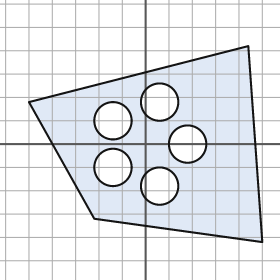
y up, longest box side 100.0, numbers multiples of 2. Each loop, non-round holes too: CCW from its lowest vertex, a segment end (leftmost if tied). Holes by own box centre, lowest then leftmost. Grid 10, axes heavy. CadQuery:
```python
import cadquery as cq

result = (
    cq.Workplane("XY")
    .moveTo(50.0, -42.0)
    .lineTo(44.0, 42.0)
    .lineTo(-50.0, 18.0)
    .lineTo(-22.0, -32.0)
    .close()
    .moveTo(6.0, -18.0)
    .circle(8.0)
    .moveTo(-14.0, -10.0)
    .circle(8.0)
    .moveTo(18.0, 0.0)
    .circle(8.0)
    .moveTo(-14.0, 10.0)
    .circle(8.0)
    .moveTo(6.0, 18.0)
    .circle(8.0)
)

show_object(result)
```